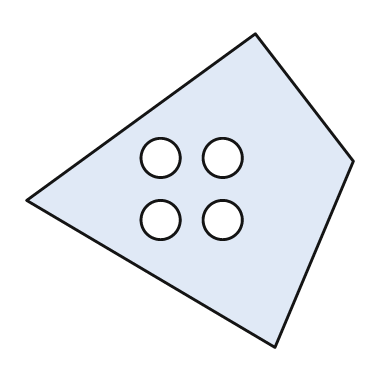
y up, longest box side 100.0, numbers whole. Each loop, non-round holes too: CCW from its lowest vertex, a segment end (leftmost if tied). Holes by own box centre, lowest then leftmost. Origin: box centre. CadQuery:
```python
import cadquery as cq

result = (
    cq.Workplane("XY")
    .moveTo(26.0, -48.0)
    .lineTo(50.0, 9.0)
    .lineTo(20.0, 48.0)
    .lineTo(-50.0, -3.0)
    .close()
    .moveTo(-9.0, -9.0)
    .circle(6.0)
    .moveTo(10.0, -9.0)
    .circle(6.0)
    .moveTo(-9.0, 10.0)
    .circle(6.0)
    .moveTo(10.0, 10.0)
    .circle(6.0)
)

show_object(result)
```